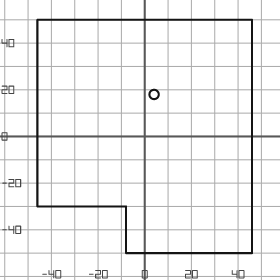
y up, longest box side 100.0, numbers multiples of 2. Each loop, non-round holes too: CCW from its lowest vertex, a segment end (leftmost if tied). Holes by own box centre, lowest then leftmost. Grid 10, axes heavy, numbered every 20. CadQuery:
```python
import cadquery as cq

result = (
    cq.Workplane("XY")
    .moveTo(-8.0, -50.0)
    .lineTo(46.0, -50.0)
    .lineTo(46.0, 50.0)
    .lineTo(-46.0, 50.0)
    .lineTo(-46.0, -30.0)
    .lineTo(-8.0, -30.0)
    .close()
    .moveTo(4.0, 18.0)
    .circle(2.0)
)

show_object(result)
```